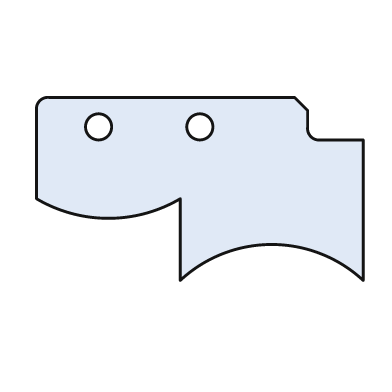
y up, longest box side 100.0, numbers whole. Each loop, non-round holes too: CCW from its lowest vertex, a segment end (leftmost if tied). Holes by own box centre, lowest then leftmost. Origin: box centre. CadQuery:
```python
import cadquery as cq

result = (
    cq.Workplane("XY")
    .moveTo(-6.0, -28.0)
    .threePointArc((22.0, -17.0), (50.0, -28.0))
    .lineTo(50.0, 15.0)
    .lineTo(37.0, 15.0)
    .threePointArc((34.0, 16.0), (33.0, 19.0))
    .lineTo(33.0, 24.0)
    .lineTo(29.0, 28.0)
    .lineTo(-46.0, 28.0)
    .threePointArc((-49.0, 27.0), (-50.0, 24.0))
    .lineTo(-50.0, -3.0)
    .threePointArc((-28.0, -9.0), (-6.0, -3.0))
    .close()
    .moveTo(-31.0, 19.0)
    .circle(4.0)
    .moveTo(0.0, 19.0)
    .circle(4.0)
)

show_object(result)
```